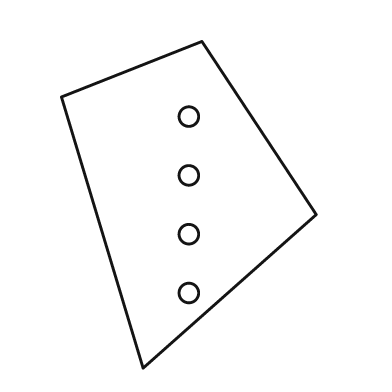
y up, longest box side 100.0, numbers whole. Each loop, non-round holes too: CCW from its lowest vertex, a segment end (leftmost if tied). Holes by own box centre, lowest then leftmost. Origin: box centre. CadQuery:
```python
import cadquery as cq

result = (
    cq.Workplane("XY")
    .moveTo(-14.0, -50.0)
    .lineTo(39.0, -3.0)
    .lineTo(4.0, 50.0)
    .lineTo(-39.0, 33.0)
    .close()
    .moveTo(0.0, -27.0)
    .circle(3.0)
    .moveTo(0.0, -9.0)
    .circle(3.0)
    .moveTo(0.0, 9.0)
    .circle(3.0)
    .moveTo(0.0, 27.0)
    .circle(3.0)
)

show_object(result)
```